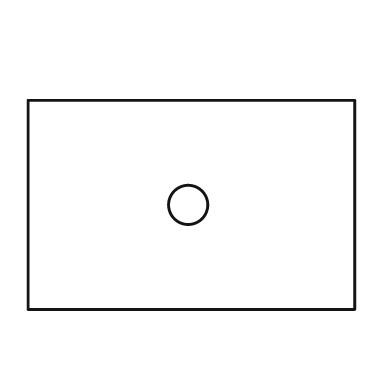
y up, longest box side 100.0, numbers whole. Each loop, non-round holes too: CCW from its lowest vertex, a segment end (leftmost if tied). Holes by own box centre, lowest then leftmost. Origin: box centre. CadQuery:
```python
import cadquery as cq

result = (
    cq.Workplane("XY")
    .moveTo(-50.0, -32.0)
    .lineTo(50.0, -32.0)
    .lineTo(50.0, 32.0)
    .lineTo(-50.0, 32.0)
    .close()
    .moveTo(-1.0, 0.0)
    .circle(6.0)
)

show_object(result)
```